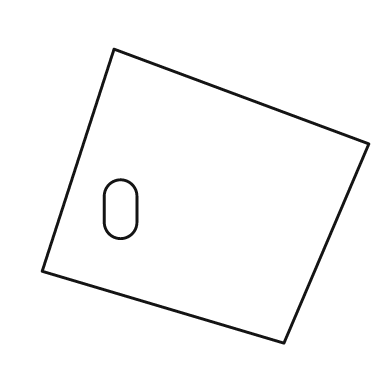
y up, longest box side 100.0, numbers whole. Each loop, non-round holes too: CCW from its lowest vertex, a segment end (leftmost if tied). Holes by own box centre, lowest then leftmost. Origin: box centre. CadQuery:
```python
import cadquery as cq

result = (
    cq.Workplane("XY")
    .moveTo(24.0, -45.0)
    .lineTo(50.0, 16.0)
    .lineTo(-28.0, 45.0)
    .lineTo(-50.0, -23.0)
    .close()
    .moveTo(-31.0, -8.0)
    .threePointArc((-26.0, -13.0), (-21.0, -8.0))
    .lineTo(-21.0, 0.0)
    .threePointArc((-26.0, 5.0), (-31.0, 0.0))
    .close()
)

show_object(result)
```